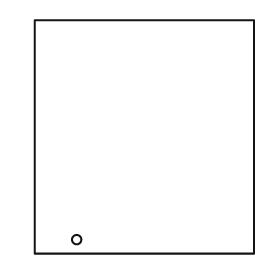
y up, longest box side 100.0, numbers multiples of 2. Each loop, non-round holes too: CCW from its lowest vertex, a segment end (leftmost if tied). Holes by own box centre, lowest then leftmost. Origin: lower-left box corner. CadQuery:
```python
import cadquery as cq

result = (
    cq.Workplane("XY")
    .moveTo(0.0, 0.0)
    .lineTo(94.0, 0.0)
    .lineTo(94.0, 100.0)
    .lineTo(0.0, 100.0)
    .close()
    .moveTo(18.0, 6.0)
    .circle(2.0)
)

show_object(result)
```